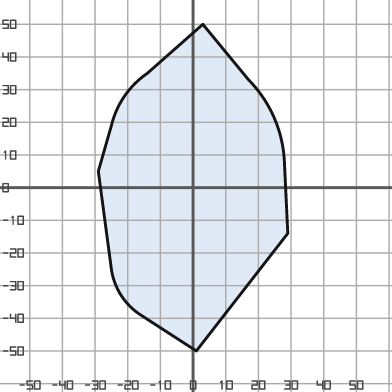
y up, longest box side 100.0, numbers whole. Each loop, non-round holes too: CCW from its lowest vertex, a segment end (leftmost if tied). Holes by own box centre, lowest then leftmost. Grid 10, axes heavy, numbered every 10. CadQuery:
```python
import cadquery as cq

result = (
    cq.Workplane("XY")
    .moveTo(1.0, -50.0)
    .lineTo(29.0, -14.0)
    .lineTo(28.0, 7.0)
    .threePointArc((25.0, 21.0), (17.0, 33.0))
    .lineTo(3.0, 50.0)
    .lineTo(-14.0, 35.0)
    .threePointArc((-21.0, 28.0), (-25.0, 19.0))
    .lineTo(-29.0, 5.0)
    .lineTo(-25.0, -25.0)
    .threePointArc((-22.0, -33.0), (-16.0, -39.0))
    .close()
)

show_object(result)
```